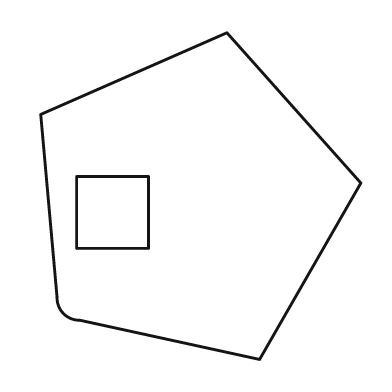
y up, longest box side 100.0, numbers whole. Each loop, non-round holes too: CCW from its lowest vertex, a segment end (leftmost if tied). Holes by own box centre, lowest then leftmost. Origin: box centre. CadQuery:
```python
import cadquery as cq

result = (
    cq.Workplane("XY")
    .moveTo(18.0, -50.0)
    .lineTo(49.0, 4.0)
    .lineTo(8.0, 50.0)
    .lineTo(-49.0, 25.0)
    .lineTo(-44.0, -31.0)
    .threePointArc((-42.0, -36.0), (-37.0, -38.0))
    .close()
    .moveTo(-38.0, -16.0)
    .lineTo(-16.0, -16.0)
    .lineTo(-16.0, 6.0)
    .lineTo(-38.0, 6.0)
    .close()
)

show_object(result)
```